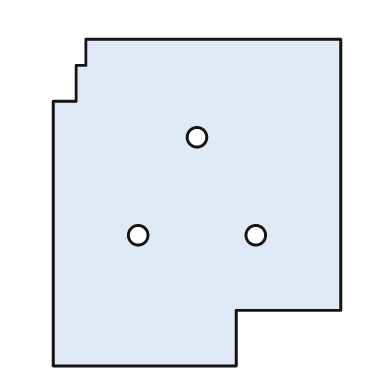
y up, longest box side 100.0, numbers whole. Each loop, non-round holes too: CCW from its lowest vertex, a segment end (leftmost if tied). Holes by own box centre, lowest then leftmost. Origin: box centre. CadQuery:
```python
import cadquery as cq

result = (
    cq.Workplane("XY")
    .moveTo(-44.0, -50.0)
    .lineTo(12.0, -50.0)
    .lineTo(12.0, -33.0)
    .lineTo(44.0, -33.0)
    .lineTo(44.0, 50.0)
    .lineTo(-34.0, 50.0)
    .lineTo(-34.0, 42.0)
    .lineTo(-37.0, 42.0)
    .lineTo(-37.0, 31.0)
    .lineTo(-44.0, 31.0)
    .close()
    .moveTo(-18.0, -10.0)
    .circle(3.0)
    .moveTo(18.0, -10.0)
    .circle(3.0)
    .moveTo(0.0, 20.0)
    .circle(3.0)
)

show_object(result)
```